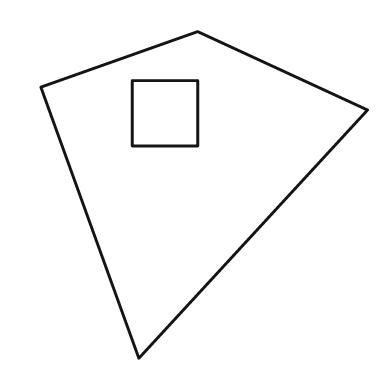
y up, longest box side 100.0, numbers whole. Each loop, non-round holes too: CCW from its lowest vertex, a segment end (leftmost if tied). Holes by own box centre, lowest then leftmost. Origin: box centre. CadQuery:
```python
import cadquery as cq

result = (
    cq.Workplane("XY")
    .moveTo(-20.0, -50.0)
    .lineTo(50.0, 26.0)
    .lineTo(-2.0, 50.0)
    .lineTo(-50.0, 33.0)
    .close()
    .moveTo(-22.0, 15.0)
    .lineTo(-2.0, 15.0)
    .lineTo(-2.0, 35.0)
    .lineTo(-22.0, 35.0)
    .close()
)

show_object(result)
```